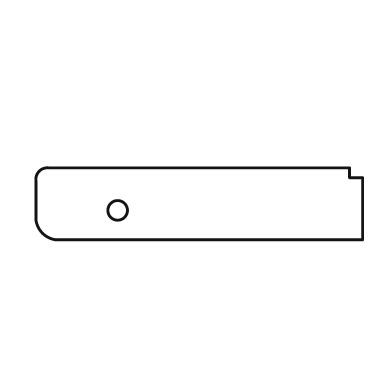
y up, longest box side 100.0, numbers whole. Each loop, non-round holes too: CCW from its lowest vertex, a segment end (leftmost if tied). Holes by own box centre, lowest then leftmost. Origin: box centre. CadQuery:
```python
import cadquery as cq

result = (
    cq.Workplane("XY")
    .moveTo(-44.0, -11.0)
    .lineTo(50.0, -11.0)
    .lineTo(50.0, 8.0)
    .lineTo(46.0, 8.0)
    .lineTo(46.0, 11.0)
    .lineTo(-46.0, 11.0)
    .threePointArc((-49.0, 10.0), (-50.0, 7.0))
    .lineTo(-50.0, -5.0)
    .threePointArc((-48.0, -9.0), (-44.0, -11.0))
    .close()
    .moveTo(-25.0, -2.0)
    .circle(3.0)
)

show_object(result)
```